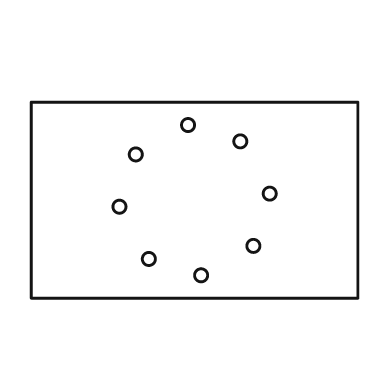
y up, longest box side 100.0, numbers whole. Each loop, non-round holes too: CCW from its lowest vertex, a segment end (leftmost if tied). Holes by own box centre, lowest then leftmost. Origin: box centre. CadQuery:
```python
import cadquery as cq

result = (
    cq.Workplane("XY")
    .moveTo(-50.0, -30.0)
    .lineTo(50.0, -30.0)
    .lineTo(50.0, 30.0)
    .lineTo(-50.0, 30.0)
    .close()
    .moveTo(2.0, -23.0)
    .circle(2.0)
    .moveTo(-14.0, -18.0)
    .circle(2.0)
    .moveTo(18.0, -14.0)
    .circle(2.0)
    .moveTo(-23.0, -2.0)
    .circle(2.0)
    .moveTo(23.0, 2.0)
    .circle(2.0)
    .moveTo(-18.0, 14.0)
    .circle(2.0)
    .moveTo(14.0, 18.0)
    .circle(2.0)
    .moveTo(-2.0, 23.0)
    .circle(2.0)
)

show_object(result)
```